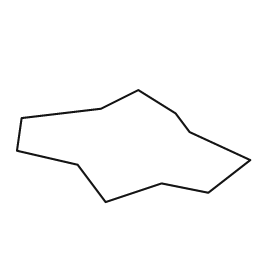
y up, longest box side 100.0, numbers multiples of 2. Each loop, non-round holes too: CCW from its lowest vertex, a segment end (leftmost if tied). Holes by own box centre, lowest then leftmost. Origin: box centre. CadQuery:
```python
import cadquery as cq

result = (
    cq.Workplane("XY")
    .moveTo(-12.0, -24.0)
    .lineTo(12.0, -16.0)
    .lineTo(32.0, -20.0)
    .lineTo(50.0, -6.0)
    .lineTo(24.0, 6.0)
    .lineTo(18.0, 14.0)
    .lineTo(2.0, 24.0)
    .lineTo(-14.0, 16.0)
    .lineTo(-48.0, 12.0)
    .lineTo(-50.0, -2.0)
    .lineTo(-24.0, -8.0)
    .close()
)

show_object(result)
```